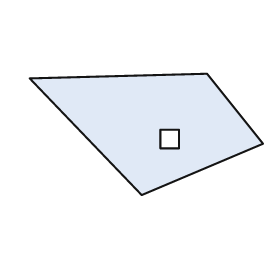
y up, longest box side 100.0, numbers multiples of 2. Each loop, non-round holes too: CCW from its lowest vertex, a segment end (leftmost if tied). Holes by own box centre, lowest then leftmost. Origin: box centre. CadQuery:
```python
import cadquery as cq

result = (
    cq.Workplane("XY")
    .moveTo(-2.0, -26.0)
    .lineTo(50.0, -4.0)
    .lineTo(26.0, 26.0)
    .lineTo(-50.0, 24.0)
    .close()
    .moveTo(6.0, -6.0)
    .lineTo(14.0, -6.0)
    .lineTo(14.0, 2.0)
    .lineTo(6.0, 2.0)
    .close()
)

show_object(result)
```